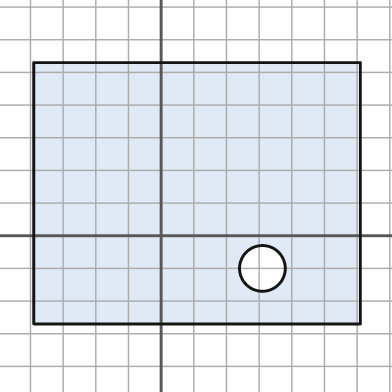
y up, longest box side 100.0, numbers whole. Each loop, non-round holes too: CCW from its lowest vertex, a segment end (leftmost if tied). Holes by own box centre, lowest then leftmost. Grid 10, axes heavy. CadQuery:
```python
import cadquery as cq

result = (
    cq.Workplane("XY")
    .moveTo(-39.0, -27.0)
    .lineTo(61.0, -27.0)
    .lineTo(61.0, 53.0)
    .lineTo(-39.0, 53.0)
    .close()
    .moveTo(31.0, -10.0)
    .circle(7.0)
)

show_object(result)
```